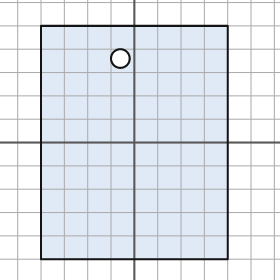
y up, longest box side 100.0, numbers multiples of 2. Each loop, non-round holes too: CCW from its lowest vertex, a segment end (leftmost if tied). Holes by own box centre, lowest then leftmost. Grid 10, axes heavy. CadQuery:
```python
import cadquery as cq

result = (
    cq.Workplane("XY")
    .moveTo(-40.0, -50.0)
    .lineTo(40.0, -50.0)
    .lineTo(40.0, 50.0)
    .lineTo(-40.0, 50.0)
    .close()
    .moveTo(-6.0, 36.0)
    .circle(4.0)
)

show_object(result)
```